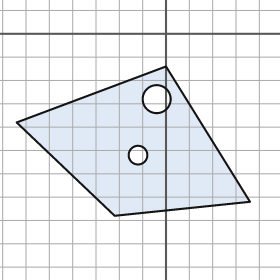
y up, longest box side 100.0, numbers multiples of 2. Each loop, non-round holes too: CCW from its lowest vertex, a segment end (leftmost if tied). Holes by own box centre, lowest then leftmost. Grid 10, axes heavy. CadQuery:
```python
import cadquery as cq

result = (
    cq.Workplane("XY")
    .moveTo(-22.0, -78.0)
    .lineTo(36.0, -72.0)
    .lineTo(0.0, -14.0)
    .lineTo(-64.0, -38.0)
    .close()
    .moveTo(-12.0, -52.0)
    .circle(4.0)
    .moveTo(-4.0, -28.0)
    .circle(6.0)
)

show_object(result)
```